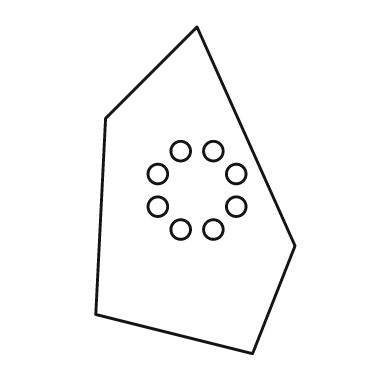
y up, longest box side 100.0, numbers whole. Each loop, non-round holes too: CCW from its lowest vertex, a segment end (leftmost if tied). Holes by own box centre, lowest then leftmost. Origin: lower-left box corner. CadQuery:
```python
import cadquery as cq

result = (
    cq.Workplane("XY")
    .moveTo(48.0, 0.0)
    .lineTo(61.0, 33.0)
    .lineTo(31.0, 100.0)
    .lineTo(3.0, 72.0)
    .lineTo(0.0, 12.0)
    .close()
    .moveTo(26.0, 38.0)
    .circle(3.0)
    .moveTo(36.0, 38.0)
    .circle(3.0)
    .moveTo(19.0, 45.0)
    .circle(3.0)
    .moveTo(43.0, 45.0)
    .circle(3.0)
    .moveTo(19.0, 55.0)
    .circle(3.0)
    .moveTo(43.0, 55.0)
    .circle(3.0)
    .moveTo(26.0, 62.0)
    .circle(3.0)
    .moveTo(36.0, 62.0)
    .circle(3.0)
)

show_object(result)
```